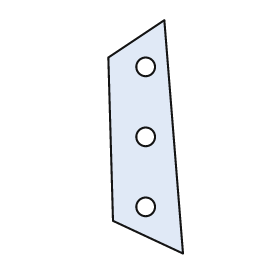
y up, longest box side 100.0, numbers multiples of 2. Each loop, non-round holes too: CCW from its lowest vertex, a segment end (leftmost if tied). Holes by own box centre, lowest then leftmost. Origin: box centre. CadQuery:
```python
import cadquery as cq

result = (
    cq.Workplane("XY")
    .moveTo(16.0, -50.0)
    .lineTo(8.0, 50.0)
    .lineTo(-16.0, 34.0)
    .lineTo(-14.0, -36.0)
    .close()
    .moveTo(0.0, -30.0)
    .circle(4.0)
    .moveTo(0.0, 0.0)
    .circle(4.0)
    .moveTo(0.0, 30.0)
    .circle(4.0)
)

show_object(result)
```